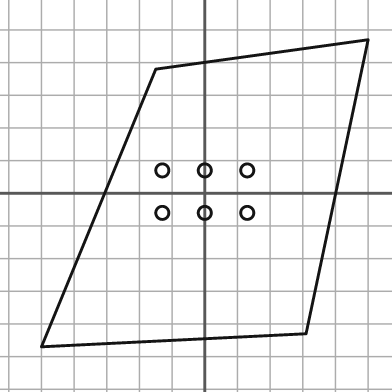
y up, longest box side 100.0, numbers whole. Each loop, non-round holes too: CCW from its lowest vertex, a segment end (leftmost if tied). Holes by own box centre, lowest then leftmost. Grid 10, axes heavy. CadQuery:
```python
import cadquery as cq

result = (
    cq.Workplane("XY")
    .moveTo(-50.0, -47.0)
    .lineTo(31.0, -43.0)
    .lineTo(50.0, 47.0)
    .lineTo(-15.0, 38.0)
    .close()
    .moveTo(-13.0, -6.0)
    .circle(2.0)
    .moveTo(0.0, -6.0)
    .circle(2.0)
    .moveTo(13.0, -6.0)
    .circle(2.0)
    .moveTo(-13.0, 7.0)
    .circle(2.0)
    .moveTo(0.0, 7.0)
    .circle(2.0)
    .moveTo(13.0, 7.0)
    .circle(2.0)
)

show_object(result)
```